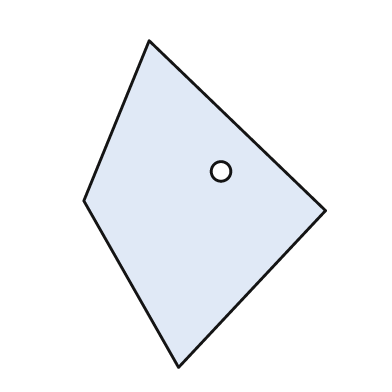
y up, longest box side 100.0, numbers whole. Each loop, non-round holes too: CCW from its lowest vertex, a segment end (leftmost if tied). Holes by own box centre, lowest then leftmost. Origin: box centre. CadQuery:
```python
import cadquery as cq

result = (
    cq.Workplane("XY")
    .moveTo(-8.0, -50.0)
    .lineTo(37.0, -2.0)
    .lineTo(-17.0, 50.0)
    .lineTo(-37.0, 1.0)
    .close()
    .moveTo(5.0, 10.0)
    .circle(3.0)
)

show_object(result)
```